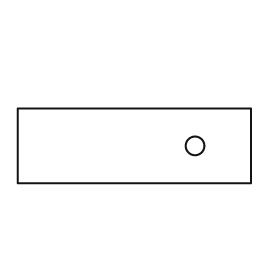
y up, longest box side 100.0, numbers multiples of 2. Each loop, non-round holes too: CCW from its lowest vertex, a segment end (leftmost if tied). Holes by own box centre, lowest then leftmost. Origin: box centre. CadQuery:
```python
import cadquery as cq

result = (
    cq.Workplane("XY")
    .moveTo(-50.0, -16.0)
    .lineTo(50.0, -16.0)
    .lineTo(50.0, 16.0)
    .lineTo(-50.0, 16.0)
    .close()
    .moveTo(26.0, 0.0)
    .circle(4.0)
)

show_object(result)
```